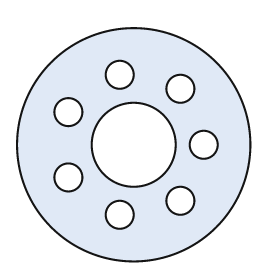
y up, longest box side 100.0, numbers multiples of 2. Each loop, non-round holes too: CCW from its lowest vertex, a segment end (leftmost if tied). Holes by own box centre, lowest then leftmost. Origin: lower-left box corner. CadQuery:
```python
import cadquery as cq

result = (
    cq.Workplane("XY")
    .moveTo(50.0, 50.0)
    .circle(50.0)
    .moveTo(44.0, 20.0)
    .circle(6.0)
    .moveTo(70.0, 26.0)
    .circle(6.0)
    .moveTo(22.0, 36.0)
    .circle(6.0)
    .moveTo(50.0, 50.0)
    .circle(18.0)
    .moveTo(80.0, 50.0)
    .circle(6.0)
    .moveTo(22.0, 64.0)
    .circle(6.0)
    .moveTo(70.0, 74.0)
    .circle(6.0)
    .moveTo(44.0, 80.0)
    .circle(6.0)
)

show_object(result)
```